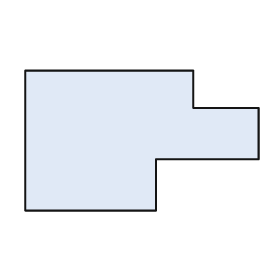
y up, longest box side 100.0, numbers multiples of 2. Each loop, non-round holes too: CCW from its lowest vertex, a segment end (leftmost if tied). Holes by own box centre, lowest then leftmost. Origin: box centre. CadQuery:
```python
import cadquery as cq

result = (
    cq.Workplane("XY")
    .moveTo(-50.0, -30.0)
    .lineTo(6.0, -30.0)
    .lineTo(6.0, -8.0)
    .lineTo(50.0, -8.0)
    .lineTo(50.0, 14.0)
    .lineTo(22.0, 14.0)
    .lineTo(22.0, 30.0)
    .lineTo(-50.0, 30.0)
    .close()
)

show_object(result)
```